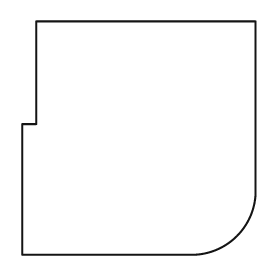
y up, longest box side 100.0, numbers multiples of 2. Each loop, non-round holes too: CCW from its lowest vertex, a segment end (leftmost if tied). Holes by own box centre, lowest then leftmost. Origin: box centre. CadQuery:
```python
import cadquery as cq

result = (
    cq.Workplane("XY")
    .moveTo(-50.0, -50.0)
    .lineTo(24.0, -50.0)
    .threePointArc((42.0, -42.0), (50.0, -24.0))
    .lineTo(50.0, 50.0)
    .lineTo(-44.0, 50.0)
    .lineTo(-44.0, 6.0)
    .lineTo(-50.0, 6.0)
    .close()
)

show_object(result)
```